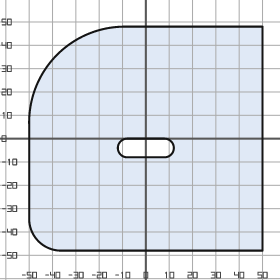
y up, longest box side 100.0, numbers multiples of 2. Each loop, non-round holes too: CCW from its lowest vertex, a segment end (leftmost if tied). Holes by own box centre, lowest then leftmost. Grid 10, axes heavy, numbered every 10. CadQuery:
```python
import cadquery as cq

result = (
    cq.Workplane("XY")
    .moveTo(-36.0, -48.0)
    .lineTo(50.0, -48.0)
    .lineTo(50.0, 48.0)
    .lineTo(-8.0, 48.0)
    .threePointArc((-38.0, 36.0), (-50.0, 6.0))
    .lineTo(-50.0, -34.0)
    .threePointArc((-46.0, -44.0), (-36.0, -48.0))
    .close()
    .moveTo(-8.0, -8.0)
    .lineTo(8.0, -8.0)
    .threePointArc((12.0, -4.0), (8.0, 0.0))
    .lineTo(-8.0, 0.0)
    .threePointArc((-12.0, -4.0), (-8.0, -8.0))
    .close()
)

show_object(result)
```